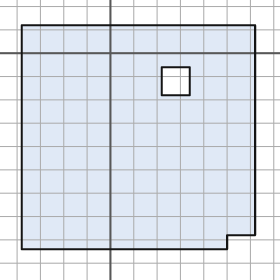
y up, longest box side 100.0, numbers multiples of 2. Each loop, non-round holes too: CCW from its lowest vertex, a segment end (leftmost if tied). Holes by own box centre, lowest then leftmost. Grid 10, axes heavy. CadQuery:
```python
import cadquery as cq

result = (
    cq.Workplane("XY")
    .moveTo(-38.0, -84.0)
    .lineTo(50.0, -84.0)
    .lineTo(50.0, -78.0)
    .lineTo(62.0, -78.0)
    .lineTo(62.0, 12.0)
    .lineTo(-38.0, 12.0)
    .close()
    .moveTo(22.0, -18.0)
    .lineTo(34.0, -18.0)
    .lineTo(34.0, -6.0)
    .lineTo(22.0, -6.0)
    .close()
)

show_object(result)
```